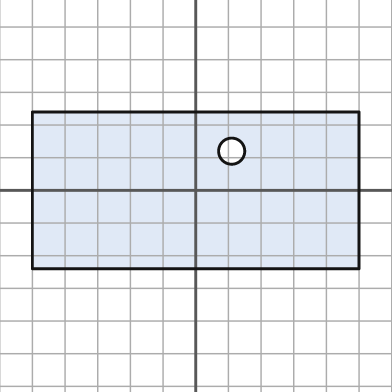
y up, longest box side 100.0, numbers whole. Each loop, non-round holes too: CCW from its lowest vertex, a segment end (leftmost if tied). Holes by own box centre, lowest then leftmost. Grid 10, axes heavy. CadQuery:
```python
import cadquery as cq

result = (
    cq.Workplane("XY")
    .moveTo(-50.0, -24.0)
    .lineTo(50.0, -24.0)
    .lineTo(50.0, 24.0)
    .lineTo(-50.0, 24.0)
    .close()
    .moveTo(11.0, 12.0)
    .circle(4.0)
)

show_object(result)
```